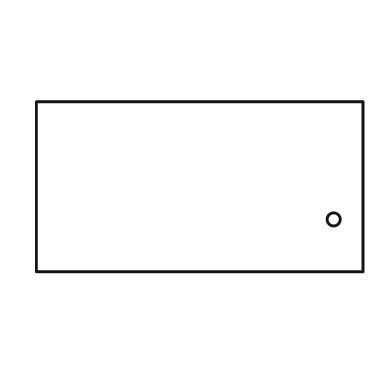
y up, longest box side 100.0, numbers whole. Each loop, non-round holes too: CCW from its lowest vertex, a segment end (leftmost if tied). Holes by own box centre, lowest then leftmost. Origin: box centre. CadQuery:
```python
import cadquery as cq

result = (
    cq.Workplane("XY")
    .moveTo(-50.0, -26.0)
    .lineTo(50.0, -26.0)
    .lineTo(50.0, 26.0)
    .lineTo(-50.0, 26.0)
    .close()
    .moveTo(41.0, -10.0)
    .circle(2.0)
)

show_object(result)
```